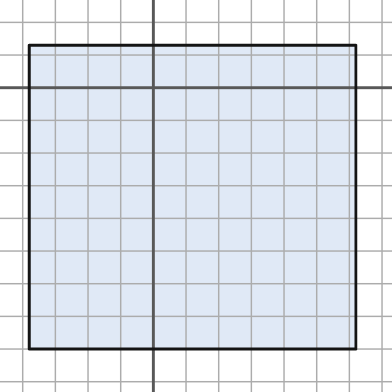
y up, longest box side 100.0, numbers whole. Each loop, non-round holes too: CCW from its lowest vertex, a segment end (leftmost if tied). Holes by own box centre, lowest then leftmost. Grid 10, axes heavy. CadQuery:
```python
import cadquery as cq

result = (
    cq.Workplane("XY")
    .moveTo(-38.0, -80.0)
    .lineTo(62.0, -80.0)
    .lineTo(62.0, 13.0)
    .lineTo(-38.0, 13.0)
    .close()
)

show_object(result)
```